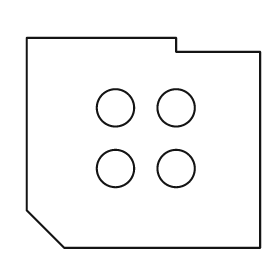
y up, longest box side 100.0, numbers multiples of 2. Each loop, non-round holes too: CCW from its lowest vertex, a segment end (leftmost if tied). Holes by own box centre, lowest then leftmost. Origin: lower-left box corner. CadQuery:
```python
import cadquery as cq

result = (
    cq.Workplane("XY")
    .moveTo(16.0, 0.0)
    .lineTo(100.0, 0.0)
    .lineTo(100.0, 84.0)
    .lineTo(64.0, 84.0)
    .lineTo(64.0, 90.0)
    .lineTo(0.0, 90.0)
    .lineTo(0.0, 16.0)
    .close()
    .moveTo(38.0, 34.0)
    .circle(8.0)
    .moveTo(64.0, 34.0)
    .circle(8.0)
    .moveTo(38.0, 60.0)
    .circle(8.0)
    .moveTo(64.0, 60.0)
    .circle(8.0)
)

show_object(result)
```